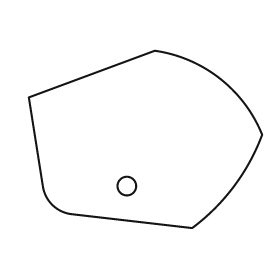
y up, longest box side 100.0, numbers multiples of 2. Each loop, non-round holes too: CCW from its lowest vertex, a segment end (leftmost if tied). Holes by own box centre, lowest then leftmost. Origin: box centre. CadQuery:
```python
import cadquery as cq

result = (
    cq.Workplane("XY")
    .moveTo(20.0, -38.0)
    .threePointArc((38.0, -20.0), (50.0, 2.0))
    .threePointArc((32.0, 26.0), (4.0, 38.0))
    .lineTo(-50.0, 18.0)
    .lineTo(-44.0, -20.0)
    .threePointArc((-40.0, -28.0), (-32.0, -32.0))
    .close()
    .moveTo(-8.0, -20.0)
    .circle(4.0)
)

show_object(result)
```